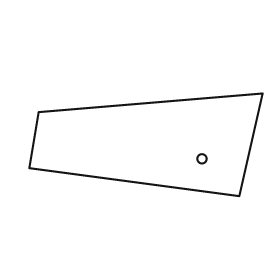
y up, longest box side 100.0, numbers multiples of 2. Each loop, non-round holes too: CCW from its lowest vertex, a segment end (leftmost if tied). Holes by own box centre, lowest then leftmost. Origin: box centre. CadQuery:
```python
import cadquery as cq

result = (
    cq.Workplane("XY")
    .moveTo(40.0, -22.0)
    .lineTo(50.0, 22.0)
    .lineTo(-46.0, 14.0)
    .lineTo(-50.0, -10.0)
    .close()
    .moveTo(24.0, -6.0)
    .circle(2.0)
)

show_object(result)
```